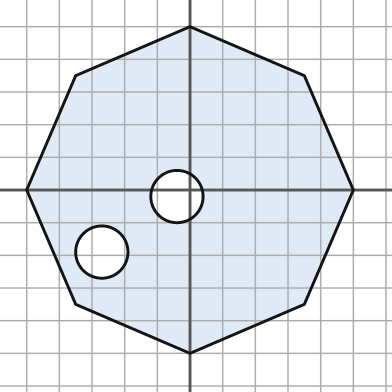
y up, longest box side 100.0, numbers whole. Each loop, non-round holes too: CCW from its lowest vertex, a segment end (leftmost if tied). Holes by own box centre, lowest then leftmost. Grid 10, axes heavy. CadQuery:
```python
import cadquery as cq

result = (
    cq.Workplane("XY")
    .moveTo(0.0, -50.0)
    .lineTo(35.0, -35.0)
    .lineTo(50.0, 0.0)
    .lineTo(35.0, 35.0)
    .lineTo(0.0, 50.0)
    .lineTo(-35.0, 35.0)
    .lineTo(-50.0, 0.0)
    .lineTo(-35.0, -35.0)
    .close()
    .moveTo(-27.0, -19.0)
    .circle(8.0)
    .moveTo(-4.0, -2.0)
    .circle(8.0)
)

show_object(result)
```